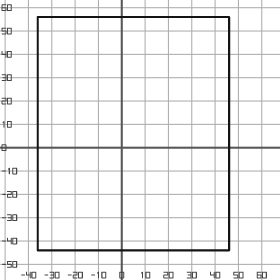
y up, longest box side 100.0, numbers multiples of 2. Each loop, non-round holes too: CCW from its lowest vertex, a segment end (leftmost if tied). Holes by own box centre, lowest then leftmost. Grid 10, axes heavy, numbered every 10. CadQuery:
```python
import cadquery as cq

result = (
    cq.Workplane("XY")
    .moveTo(-36.0, -44.0)
    .lineTo(46.0, -44.0)
    .lineTo(46.0, 56.0)
    .lineTo(-36.0, 56.0)
    .close()
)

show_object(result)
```